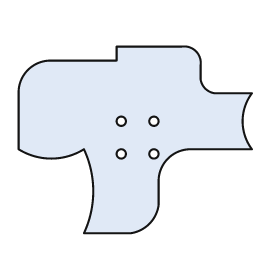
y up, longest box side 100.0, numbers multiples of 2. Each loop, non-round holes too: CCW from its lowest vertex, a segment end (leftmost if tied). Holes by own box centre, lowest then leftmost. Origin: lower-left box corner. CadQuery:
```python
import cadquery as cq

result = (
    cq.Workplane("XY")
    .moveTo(28.0, 0.0)
    .lineTo(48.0, 0.0)
    .threePointArc((56.0, 4.0), (60.0, 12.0))
    .lineTo(60.0, 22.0)
    .threePointArc((64.0, 32.0), (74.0, 36.0))
    .lineTo(100.0, 36.0)
    .threePointArc((96.0, 48.0), (100.0, 60.0))
    .lineTo(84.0, 60.0)
    .threePointArc((80.0, 62.0), (78.0, 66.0))
    .lineTo(78.0, 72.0)
    .threePointArc((76.0, 78.0), (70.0, 80.0))
    .lineTo(42.0, 80.0)
    .lineTo(42.0, 74.0)
    .lineTo(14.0, 74.0)
    .threePointArc((4.0, 70.0), (0.0, 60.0))
    .lineTo(0.0, 36.0)
    .threePointArc((14.0, 32.0), (28.0, 36.0))
    .threePointArc((32.0, 18.0), (28.0, 0.0))
    .close()
    .moveTo(44.0, 34.0)
    .circle(2.0)
    .moveTo(58.0, 34.0)
    .circle(2.0)
    .moveTo(44.0, 48.0)
    .circle(2.0)
    .moveTo(58.0, 48.0)
    .circle(2.0)
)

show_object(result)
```